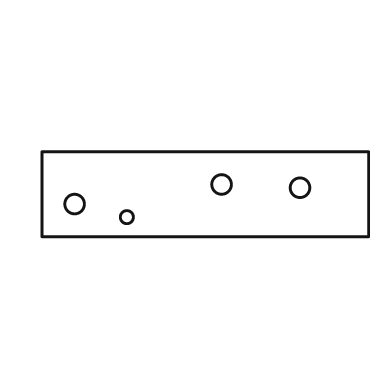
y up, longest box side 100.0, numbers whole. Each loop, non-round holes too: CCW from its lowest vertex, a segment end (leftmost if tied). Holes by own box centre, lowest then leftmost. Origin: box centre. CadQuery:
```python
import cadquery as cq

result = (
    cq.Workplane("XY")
    .moveTo(-50.0, -13.0)
    .lineTo(50.0, -13.0)
    .lineTo(50.0, 13.0)
    .lineTo(-50.0, 13.0)
    .close()
    .moveTo(-24.0, -7.0)
    .circle(2.0)
    .moveTo(-40.0, -3.0)
    .circle(3.0)
    .moveTo(29.0, 2.0)
    .circle(3.0)
    .moveTo(5.0, 3.0)
    .circle(3.0)
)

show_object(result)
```